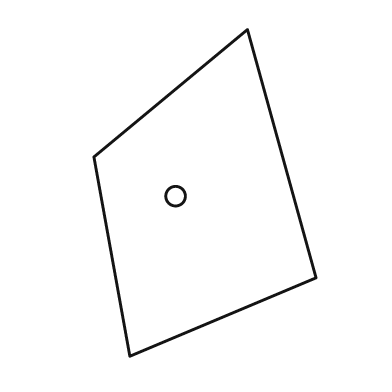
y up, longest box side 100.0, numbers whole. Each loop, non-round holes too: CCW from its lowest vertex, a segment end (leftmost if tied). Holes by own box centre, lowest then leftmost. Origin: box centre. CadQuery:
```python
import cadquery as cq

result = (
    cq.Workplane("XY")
    .moveTo(-23.0, -50.0)
    .lineTo(34.0, -26.0)
    .lineTo(13.0, 50.0)
    .lineTo(-34.0, 11.0)
    .close()
    .moveTo(-9.0, -1.0)
    .circle(3.0)
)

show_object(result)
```